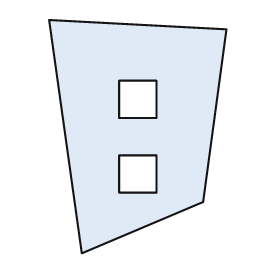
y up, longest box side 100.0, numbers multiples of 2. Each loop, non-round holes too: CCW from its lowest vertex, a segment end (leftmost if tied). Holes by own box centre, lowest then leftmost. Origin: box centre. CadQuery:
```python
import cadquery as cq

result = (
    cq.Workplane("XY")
    .moveTo(-24.0, -50.0)
    .lineTo(28.0, -28.0)
    .lineTo(38.0, 46.0)
    .lineTo(-38.0, 50.0)
    .close()
    .moveTo(-8.0, -24.0)
    .lineTo(8.0, -24.0)
    .lineTo(8.0, -8.0)
    .lineTo(-8.0, -8.0)
    .close()
    .moveTo(-8.0, 8.0)
    .lineTo(8.0, 8.0)
    .lineTo(8.0, 24.0)
    .lineTo(-8.0, 24.0)
    .close()
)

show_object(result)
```